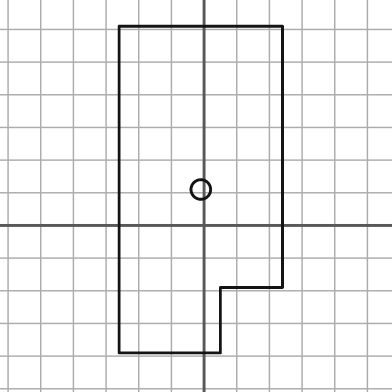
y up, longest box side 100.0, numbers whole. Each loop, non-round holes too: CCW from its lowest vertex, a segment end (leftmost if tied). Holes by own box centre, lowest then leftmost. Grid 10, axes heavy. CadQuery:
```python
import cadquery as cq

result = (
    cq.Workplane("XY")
    .moveTo(-26.0, -39.0)
    .lineTo(5.0, -39.0)
    .lineTo(5.0, -19.0)
    .lineTo(24.0, -19.0)
    .lineTo(24.0, 61.0)
    .lineTo(-26.0, 61.0)
    .close()
    .moveTo(-1.0, 11.0)
    .circle(3.0)
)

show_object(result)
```